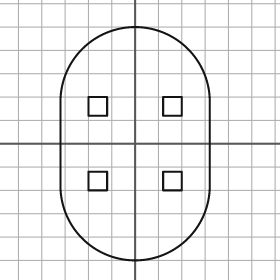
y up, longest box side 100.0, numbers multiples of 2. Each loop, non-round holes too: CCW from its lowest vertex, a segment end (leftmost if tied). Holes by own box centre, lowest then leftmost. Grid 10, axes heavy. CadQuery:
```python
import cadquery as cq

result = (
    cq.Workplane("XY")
    .moveTo(-32.0, -18.0)
    .threePointArc((0.0, -50.0), (32.0, -18.0))
    .lineTo(32.0, 18.0)
    .threePointArc((0.0, 50.0), (-32.0, 18.0))
    .close()
    .moveTo(-20.0, -20.0)
    .lineTo(-12.0, -20.0)
    .lineTo(-12.0, -12.0)
    .lineTo(-20.0, -12.0)
    .close()
    .moveTo(12.0, -20.0)
    .lineTo(20.0, -20.0)
    .lineTo(20.0, -12.0)
    .lineTo(12.0, -12.0)
    .close()
    .moveTo(-20.0, 12.0)
    .lineTo(-12.0, 12.0)
    .lineTo(-12.0, 20.0)
    .lineTo(-20.0, 20.0)
    .close()
    .moveTo(12.0, 12.0)
    .lineTo(20.0, 12.0)
    .lineTo(20.0, 20.0)
    .lineTo(12.0, 20.0)
    .close()
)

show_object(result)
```